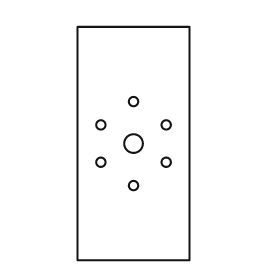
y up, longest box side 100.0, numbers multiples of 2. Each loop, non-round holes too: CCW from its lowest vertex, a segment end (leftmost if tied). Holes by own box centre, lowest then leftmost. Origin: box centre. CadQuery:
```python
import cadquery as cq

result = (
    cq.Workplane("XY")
    .moveTo(-24.0, -50.0)
    .lineTo(24.0, -50.0)
    .lineTo(24.0, 50.0)
    .lineTo(-24.0, 50.0)
    .close()
    .moveTo(0.0, -18.0)
    .circle(2.0)
    .moveTo(-14.0, -8.0)
    .circle(2.0)
    .moveTo(14.0, -8.0)
    .circle(2.0)
    .moveTo(0.0, 0.0)
    .circle(4.0)
    .moveTo(-14.0, 8.0)
    .circle(2.0)
    .moveTo(14.0, 8.0)
    .circle(2.0)
    .moveTo(0.0, 18.0)
    .circle(2.0)
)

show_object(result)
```